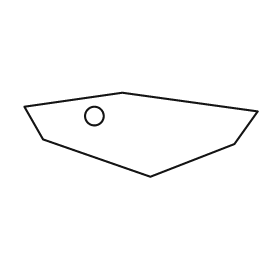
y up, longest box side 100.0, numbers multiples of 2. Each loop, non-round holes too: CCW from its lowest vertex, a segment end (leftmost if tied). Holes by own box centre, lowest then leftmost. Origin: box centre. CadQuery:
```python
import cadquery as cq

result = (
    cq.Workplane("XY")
    .moveTo(4.0, -18.0)
    .lineTo(40.0, -4.0)
    .lineTo(50.0, 10.0)
    .lineTo(-8.0, 18.0)
    .lineTo(-50.0, 12.0)
    .lineTo(-42.0, -2.0)
    .close()
    .moveTo(-20.0, 8.0)
    .circle(4.0)
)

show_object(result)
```